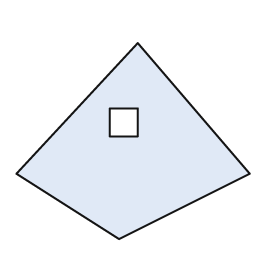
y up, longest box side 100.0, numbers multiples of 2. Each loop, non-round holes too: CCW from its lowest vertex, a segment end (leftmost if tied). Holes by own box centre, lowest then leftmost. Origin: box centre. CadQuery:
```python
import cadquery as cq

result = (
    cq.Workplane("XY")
    .moveTo(-6.0, -42.0)
    .lineTo(50.0, -14.0)
    .lineTo(2.0, 42.0)
    .lineTo(-50.0, -14.0)
    .close()
    .moveTo(-10.0, 2.0)
    .lineTo(2.0, 2.0)
    .lineTo(2.0, 14.0)
    .lineTo(-10.0, 14.0)
    .close()
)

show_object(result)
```